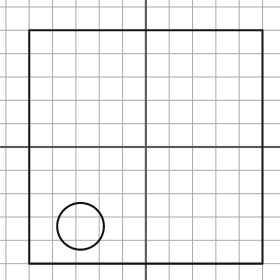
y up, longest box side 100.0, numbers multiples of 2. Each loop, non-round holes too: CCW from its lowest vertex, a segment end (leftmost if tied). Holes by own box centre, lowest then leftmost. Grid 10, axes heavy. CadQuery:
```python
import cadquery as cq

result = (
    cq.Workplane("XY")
    .moveTo(-50.0, -50.0)
    .lineTo(50.0, -50.0)
    .lineTo(50.0, 50.0)
    .lineTo(-50.0, 50.0)
    .close()
    .moveTo(-28.0, -34.0)
    .circle(10.0)
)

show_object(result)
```